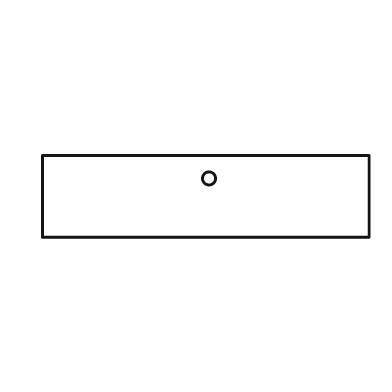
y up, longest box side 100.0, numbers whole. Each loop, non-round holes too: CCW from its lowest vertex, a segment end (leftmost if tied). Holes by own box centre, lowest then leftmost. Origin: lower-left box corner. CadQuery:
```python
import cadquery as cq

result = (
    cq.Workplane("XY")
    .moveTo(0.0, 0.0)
    .lineTo(100.0, 0.0)
    .lineTo(100.0, 25.0)
    .lineTo(0.0, 25.0)
    .close()
    .moveTo(51.0, 18.0)
    .circle(2.0)
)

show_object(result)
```